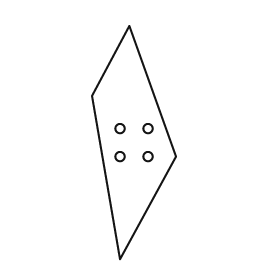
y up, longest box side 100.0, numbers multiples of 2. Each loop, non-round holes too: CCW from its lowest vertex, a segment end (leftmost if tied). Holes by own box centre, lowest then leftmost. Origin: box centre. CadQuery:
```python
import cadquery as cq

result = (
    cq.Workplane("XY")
    .moveTo(-6.0, -50.0)
    .lineTo(18.0, -6.0)
    .lineTo(-2.0, 50.0)
    .lineTo(-18.0, 20.0)
    .close()
    .moveTo(-6.0, -6.0)
    .circle(2.0)
    .moveTo(6.0, -6.0)
    .circle(2.0)
    .moveTo(-6.0, 6.0)
    .circle(2.0)
    .moveTo(6.0, 6.0)
    .circle(2.0)
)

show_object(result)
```